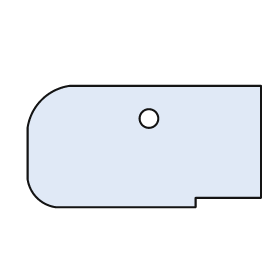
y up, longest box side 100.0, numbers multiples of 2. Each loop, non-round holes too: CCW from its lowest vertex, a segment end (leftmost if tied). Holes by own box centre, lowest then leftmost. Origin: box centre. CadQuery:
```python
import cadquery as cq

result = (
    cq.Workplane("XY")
    .moveTo(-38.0, -26.0)
    .lineTo(22.0, -26.0)
    .lineTo(22.0, -22.0)
    .lineTo(50.0, -22.0)
    .lineTo(50.0, 26.0)
    .lineTo(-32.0, 26.0)
    .threePointArc((-44.0, 20.0), (-50.0, 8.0))
    .lineTo(-50.0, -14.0)
    .threePointArc((-46.0, -22.0), (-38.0, -26.0))
    .close()
    .moveTo(2.0, 12.0)
    .circle(4.0)
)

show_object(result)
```